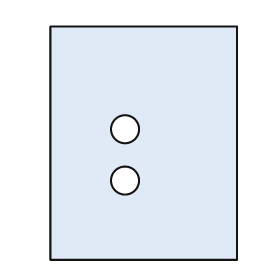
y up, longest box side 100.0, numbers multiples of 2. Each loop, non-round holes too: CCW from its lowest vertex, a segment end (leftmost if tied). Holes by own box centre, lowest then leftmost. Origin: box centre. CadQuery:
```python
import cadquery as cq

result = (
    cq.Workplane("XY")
    .moveTo(-40.0, -50.0)
    .lineTo(40.0, -50.0)
    .lineTo(40.0, 50.0)
    .lineTo(-40.0, 50.0)
    .close()
    .moveTo(-8.0, -16.0)
    .circle(6.0)
    .moveTo(-8.0, 6.0)
    .circle(6.0)
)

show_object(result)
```